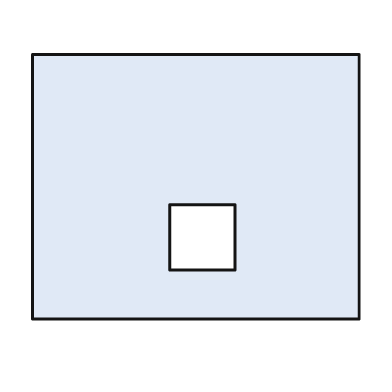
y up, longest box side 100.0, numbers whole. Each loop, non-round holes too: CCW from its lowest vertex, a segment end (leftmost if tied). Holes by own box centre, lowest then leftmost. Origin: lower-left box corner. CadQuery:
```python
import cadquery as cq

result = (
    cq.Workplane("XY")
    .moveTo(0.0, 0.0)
    .lineTo(100.0, 0.0)
    .lineTo(100.0, 81.0)
    .lineTo(0.0, 81.0)
    .close()
    .moveTo(42.0, 15.0)
    .lineTo(62.0, 15.0)
    .lineTo(62.0, 35.0)
    .lineTo(42.0, 35.0)
    .close()
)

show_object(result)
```